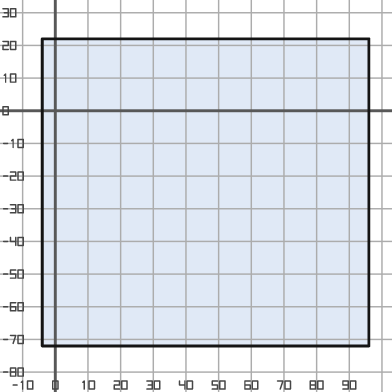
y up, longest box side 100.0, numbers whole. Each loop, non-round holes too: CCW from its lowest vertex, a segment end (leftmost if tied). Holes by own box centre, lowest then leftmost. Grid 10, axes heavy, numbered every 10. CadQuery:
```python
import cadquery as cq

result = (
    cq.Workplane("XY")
    .moveTo(-4.0, -72.0)
    .lineTo(96.0, -72.0)
    .lineTo(96.0, 22.0)
    .lineTo(-4.0, 22.0)
    .close()
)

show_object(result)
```